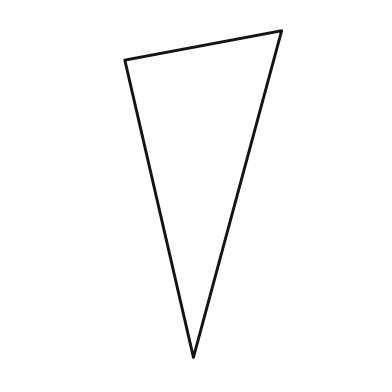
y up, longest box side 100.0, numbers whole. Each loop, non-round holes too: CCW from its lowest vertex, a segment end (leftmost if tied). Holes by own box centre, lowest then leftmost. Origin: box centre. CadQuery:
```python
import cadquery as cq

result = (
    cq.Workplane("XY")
    .moveTo(-3.0, -50.0)
    .lineTo(24.0, 50.0)
    .lineTo(-24.0, 41.0)
    .close()
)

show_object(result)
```